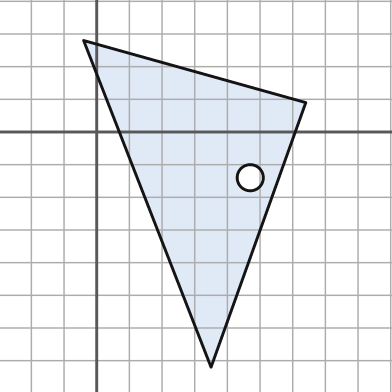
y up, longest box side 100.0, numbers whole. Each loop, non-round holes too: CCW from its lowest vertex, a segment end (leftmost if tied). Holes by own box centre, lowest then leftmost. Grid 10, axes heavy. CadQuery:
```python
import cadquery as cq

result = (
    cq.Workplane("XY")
    .moveTo(35.0, -72.0)
    .lineTo(64.0, 9.0)
    .lineTo(-4.0, 28.0)
    .close()
    .moveTo(47.0, -14.0)
    .circle(4.0)
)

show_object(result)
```